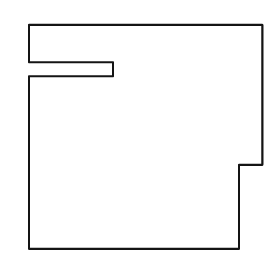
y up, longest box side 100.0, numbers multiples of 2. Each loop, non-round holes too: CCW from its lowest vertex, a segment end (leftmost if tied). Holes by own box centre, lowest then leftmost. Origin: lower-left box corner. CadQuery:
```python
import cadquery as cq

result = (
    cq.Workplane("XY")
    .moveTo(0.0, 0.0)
    .lineTo(90.0, 0.0)
    .lineTo(90.0, 36.0)
    .lineTo(100.0, 36.0)
    .lineTo(100.0, 96.0)
    .lineTo(0.0, 96.0)
    .lineTo(0.0, 80.0)
    .lineTo(36.0, 80.0)
    .lineTo(36.0, 74.0)
    .lineTo(0.0, 74.0)
    .close()
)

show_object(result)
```